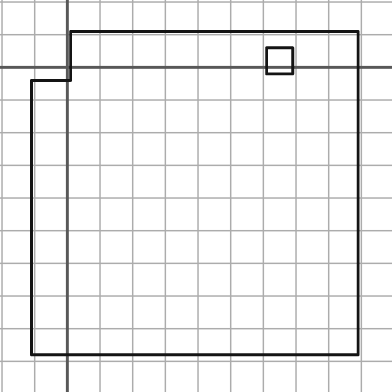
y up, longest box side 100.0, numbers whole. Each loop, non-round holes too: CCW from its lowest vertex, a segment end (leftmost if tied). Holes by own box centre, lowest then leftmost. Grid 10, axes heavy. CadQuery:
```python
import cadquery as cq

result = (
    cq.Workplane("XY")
    .moveTo(-11.0, -88.0)
    .lineTo(89.0, -88.0)
    .lineTo(89.0, 11.0)
    .lineTo(1.0, 11.0)
    .lineTo(1.0, -4.0)
    .lineTo(-11.0, -4.0)
    .close()
    .moveTo(61.0, -2.0)
    .lineTo(69.0, -2.0)
    .lineTo(69.0, 6.0)
    .lineTo(61.0, 6.0)
    .close()
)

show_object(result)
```